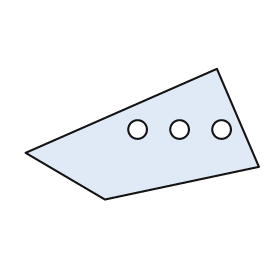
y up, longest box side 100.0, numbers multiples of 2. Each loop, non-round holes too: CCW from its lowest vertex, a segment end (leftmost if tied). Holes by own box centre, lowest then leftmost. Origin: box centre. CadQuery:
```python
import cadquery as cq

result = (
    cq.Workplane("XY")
    .moveTo(-16.0, -28.0)
    .lineTo(50.0, -14.0)
    .lineTo(32.0, 28.0)
    .lineTo(-50.0, -8.0)
    .close()
    .moveTo(-2.0, 2.0)
    .circle(4.0)
    .moveTo(16.0, 2.0)
    .circle(4.0)
    .moveTo(34.0, 2.0)
    .circle(4.0)
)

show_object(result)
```